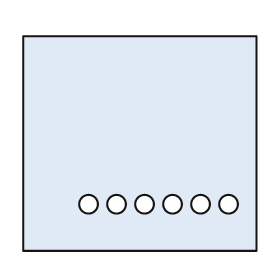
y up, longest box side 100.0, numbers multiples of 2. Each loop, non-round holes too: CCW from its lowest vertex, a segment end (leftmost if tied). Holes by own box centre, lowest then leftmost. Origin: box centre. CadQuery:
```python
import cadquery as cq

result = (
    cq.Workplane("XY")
    .moveTo(-50.0, -46.0)
    .lineTo(50.0, -46.0)
    .lineTo(50.0, 46.0)
    .lineTo(-50.0, 46.0)
    .close()
    .moveTo(-22.0, -26.0)
    .circle(4.0)
    .moveTo(-10.0, -26.0)
    .circle(4.0)
    .moveTo(2.0, -26.0)
    .circle(4.0)
    .moveTo(14.0, -26.0)
    .circle(4.0)
    .moveTo(26.0, -26.0)
    .circle(4.0)
    .moveTo(38.0, -26.0)
    .circle(4.0)
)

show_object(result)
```